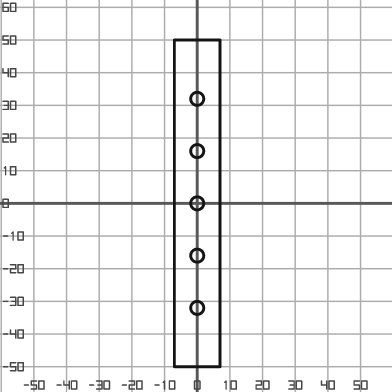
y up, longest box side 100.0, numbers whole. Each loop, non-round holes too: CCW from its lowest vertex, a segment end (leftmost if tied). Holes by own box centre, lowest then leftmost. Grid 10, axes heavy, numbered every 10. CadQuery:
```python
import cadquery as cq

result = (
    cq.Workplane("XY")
    .moveTo(-7.0, -50.0)
    .lineTo(7.0, -50.0)
    .lineTo(7.0, 50.0)
    .lineTo(-7.0, 50.0)
    .close()
    .moveTo(0.0, -32.0)
    .circle(2.0)
    .moveTo(0.0, -16.0)
    .circle(2.0)
    .moveTo(0.0, 0.0)
    .circle(2.0)
    .moveTo(0.0, 16.0)
    .circle(2.0)
    .moveTo(0.0, 32.0)
    .circle(2.0)
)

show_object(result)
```